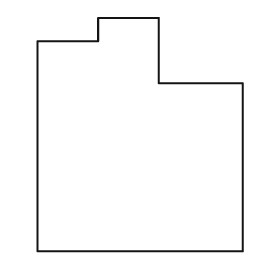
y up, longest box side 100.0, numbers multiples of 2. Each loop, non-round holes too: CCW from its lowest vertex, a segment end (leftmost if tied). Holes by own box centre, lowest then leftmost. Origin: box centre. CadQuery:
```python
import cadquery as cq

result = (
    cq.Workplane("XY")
    .moveTo(-44.0, -50.0)
    .lineTo(44.0, -50.0)
    .lineTo(44.0, 22.0)
    .lineTo(8.0, 22.0)
    .lineTo(8.0, 50.0)
    .lineTo(-18.0, 50.0)
    .lineTo(-18.0, 40.0)
    .lineTo(-44.0, 40.0)
    .close()
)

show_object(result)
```